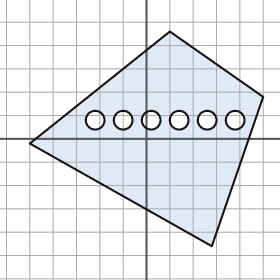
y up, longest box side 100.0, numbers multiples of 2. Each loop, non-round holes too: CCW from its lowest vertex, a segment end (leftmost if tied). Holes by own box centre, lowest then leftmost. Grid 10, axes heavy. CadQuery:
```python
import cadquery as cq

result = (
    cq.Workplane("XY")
    .moveTo(28.0, -46.0)
    .lineTo(50.0, 18.0)
    .lineTo(10.0, 46.0)
    .lineTo(-50.0, -2.0)
    .close()
    .moveTo(-22.0, 8.0)
    .circle(4.0)
    .moveTo(-10.0, 8.0)
    .circle(4.0)
    .moveTo(2.0, 8.0)
    .circle(4.0)
    .moveTo(14.0, 8.0)
    .circle(4.0)
    .moveTo(26.0, 8.0)
    .circle(4.0)
    .moveTo(38.0, 8.0)
    .circle(4.0)
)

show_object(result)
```